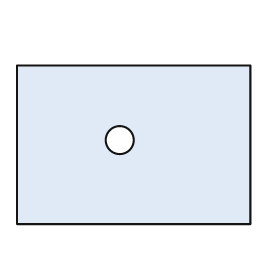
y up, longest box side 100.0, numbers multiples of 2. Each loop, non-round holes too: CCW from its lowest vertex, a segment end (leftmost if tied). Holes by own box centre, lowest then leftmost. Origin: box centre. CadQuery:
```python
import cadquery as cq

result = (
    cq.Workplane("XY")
    .moveTo(-50.0, -34.0)
    .lineTo(50.0, -34.0)
    .lineTo(50.0, 34.0)
    .lineTo(-50.0, 34.0)
    .close()
    .moveTo(-6.0, 2.0)
    .circle(6.0)
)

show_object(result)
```